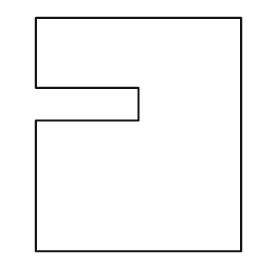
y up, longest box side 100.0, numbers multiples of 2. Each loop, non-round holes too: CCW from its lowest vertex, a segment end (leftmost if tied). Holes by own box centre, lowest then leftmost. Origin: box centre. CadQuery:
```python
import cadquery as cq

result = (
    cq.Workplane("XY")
    .moveTo(-44.0, -50.0)
    .lineTo(44.0, -50.0)
    .lineTo(44.0, 50.0)
    .lineTo(-44.0, 50.0)
    .lineTo(-44.0, 20.0)
    .lineTo(0.0, 20.0)
    .lineTo(0.0, 6.0)
    .lineTo(-44.0, 6.0)
    .close()
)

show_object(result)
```